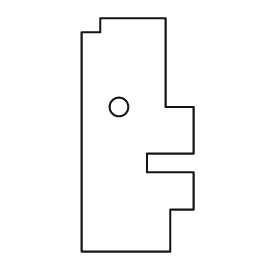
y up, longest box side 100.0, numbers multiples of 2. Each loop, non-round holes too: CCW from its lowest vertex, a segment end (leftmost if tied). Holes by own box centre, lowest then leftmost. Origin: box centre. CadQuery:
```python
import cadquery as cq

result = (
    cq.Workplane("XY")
    .moveTo(-24.0, -50.0)
    .lineTo(14.0, -50.0)
    .lineTo(14.0, -32.0)
    .lineTo(24.0, -32.0)
    .lineTo(24.0, -16.0)
    .lineTo(4.0, -16.0)
    .lineTo(4.0, -8.0)
    .lineTo(24.0, -8.0)
    .lineTo(24.0, 12.0)
    .lineTo(12.0, 12.0)
    .lineTo(12.0, 50.0)
    .lineTo(-16.0, 50.0)
    .lineTo(-16.0, 44.0)
    .lineTo(-24.0, 44.0)
    .close()
    .moveTo(-8.0, 12.0)
    .circle(4.0)
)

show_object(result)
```